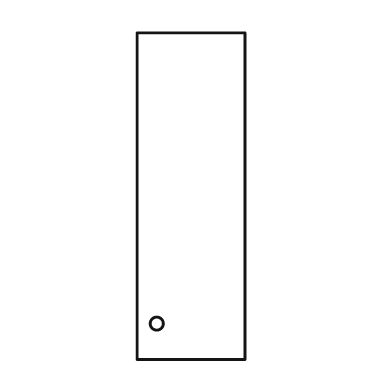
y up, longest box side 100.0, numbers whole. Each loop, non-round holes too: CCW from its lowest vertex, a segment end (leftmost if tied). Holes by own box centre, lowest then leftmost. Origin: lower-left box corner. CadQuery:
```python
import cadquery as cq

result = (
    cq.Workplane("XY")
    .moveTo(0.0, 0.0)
    .lineTo(33.0, 0.0)
    .lineTo(33.0, 100.0)
    .lineTo(0.0, 100.0)
    .close()
    .moveTo(6.0, 11.0)
    .circle(2.0)
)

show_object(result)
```